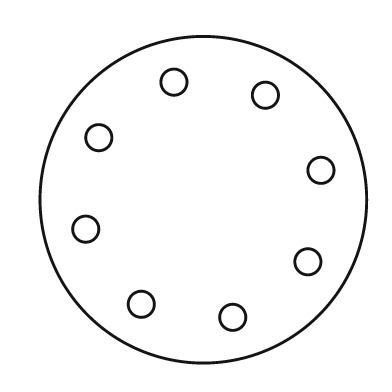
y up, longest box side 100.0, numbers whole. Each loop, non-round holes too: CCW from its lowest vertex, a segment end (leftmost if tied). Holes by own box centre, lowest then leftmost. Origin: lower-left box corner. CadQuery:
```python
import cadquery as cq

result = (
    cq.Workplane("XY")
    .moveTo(50.0, 50.0)
    .circle(50.0)
    .moveTo(59.0, 14.0)
    .circle(4.0)
    .moveTo(31.0, 18.0)
    .circle(4.0)
    .moveTo(82.0, 31.0)
    .circle(4.0)
    .moveTo(14.0, 41.0)
    .circle(4.0)
    .moveTo(86.0, 59.0)
    .circle(4.0)
    .moveTo(18.0, 69.0)
    .circle(4.0)
    .moveTo(69.0, 82.0)
    .circle(4.0)
    .moveTo(41.0, 86.0)
    .circle(4.0)
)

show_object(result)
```